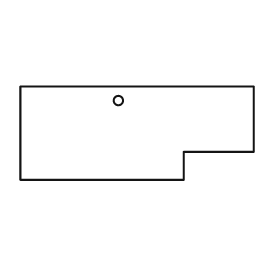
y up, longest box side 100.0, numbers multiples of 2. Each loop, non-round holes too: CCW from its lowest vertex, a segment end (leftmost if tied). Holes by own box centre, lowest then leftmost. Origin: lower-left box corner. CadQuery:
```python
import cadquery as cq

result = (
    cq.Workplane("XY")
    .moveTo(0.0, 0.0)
    .lineTo(70.0, 0.0)
    .lineTo(70.0, 12.0)
    .lineTo(100.0, 12.0)
    .lineTo(100.0, 40.0)
    .lineTo(0.0, 40.0)
    .close()
    .moveTo(42.0, 34.0)
    .circle(2.0)
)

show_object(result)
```